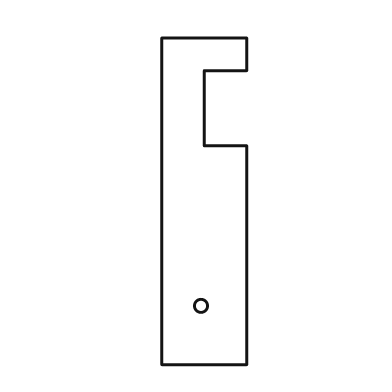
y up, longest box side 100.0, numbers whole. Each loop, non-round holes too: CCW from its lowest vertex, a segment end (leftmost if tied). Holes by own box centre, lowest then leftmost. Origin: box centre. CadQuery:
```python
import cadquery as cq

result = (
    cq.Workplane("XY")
    .moveTo(-13.0, -50.0)
    .lineTo(13.0, -50.0)
    .lineTo(13.0, 17.0)
    .lineTo(0.0, 17.0)
    .lineTo(0.0, 40.0)
    .lineTo(13.0, 40.0)
    .lineTo(13.0, 50.0)
    .lineTo(-13.0, 50.0)
    .close()
    .moveTo(-1.0, -32.0)
    .circle(2.0)
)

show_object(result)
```